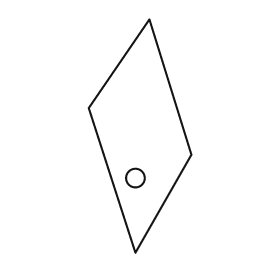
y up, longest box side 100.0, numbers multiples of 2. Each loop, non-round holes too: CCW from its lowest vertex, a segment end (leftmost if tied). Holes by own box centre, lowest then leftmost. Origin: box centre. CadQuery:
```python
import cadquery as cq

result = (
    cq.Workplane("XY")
    .moveTo(-2.0, -50.0)
    .lineTo(22.0, -8.0)
    .lineTo(4.0, 50.0)
    .lineTo(-22.0, 12.0)
    .close()
    .moveTo(-2.0, -18.0)
    .circle(4.0)
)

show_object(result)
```